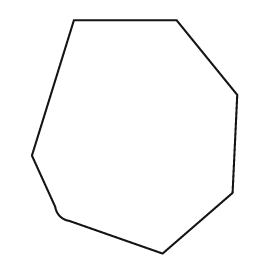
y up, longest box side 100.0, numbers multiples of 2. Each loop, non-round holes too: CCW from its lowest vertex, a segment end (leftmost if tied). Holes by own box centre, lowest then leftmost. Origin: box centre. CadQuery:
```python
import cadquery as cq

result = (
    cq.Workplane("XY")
    .moveTo(12.0, -50.0)
    .lineTo(42.0, -24.0)
    .lineTo(44.0, 18.0)
    .lineTo(18.0, 50.0)
    .lineTo(-26.0, 50.0)
    .lineTo(-44.0, -8.0)
    .lineTo(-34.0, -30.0)
    .threePointArc((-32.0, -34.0), (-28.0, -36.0))
    .close()
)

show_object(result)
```